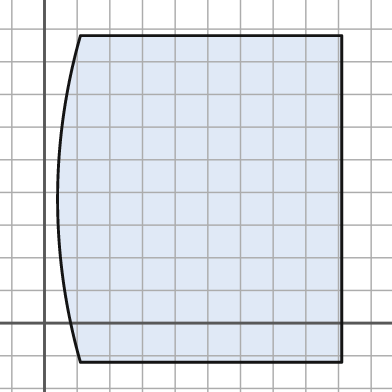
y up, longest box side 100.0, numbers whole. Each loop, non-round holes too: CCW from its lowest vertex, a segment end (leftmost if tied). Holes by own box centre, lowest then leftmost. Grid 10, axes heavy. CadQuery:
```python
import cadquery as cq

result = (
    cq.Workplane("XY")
    .moveTo(11.0, -12.0)
    .lineTo(91.0, -12.0)
    .lineTo(91.0, 88.0)
    .lineTo(11.0, 88.0)
    .threePointArc((4.0, 38.0), (11.0, -12.0))
    .close()
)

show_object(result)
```